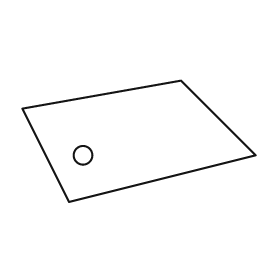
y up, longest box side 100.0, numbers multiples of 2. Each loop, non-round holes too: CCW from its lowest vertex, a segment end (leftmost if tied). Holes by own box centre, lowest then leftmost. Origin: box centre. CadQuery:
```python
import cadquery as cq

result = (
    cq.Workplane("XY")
    .moveTo(-30.0, -26.0)
    .lineTo(50.0, -6.0)
    .lineTo(18.0, 26.0)
    .lineTo(-50.0, 14.0)
    .close()
    .moveTo(-24.0, -6.0)
    .circle(4.0)
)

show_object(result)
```